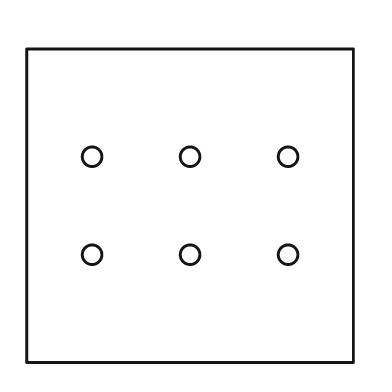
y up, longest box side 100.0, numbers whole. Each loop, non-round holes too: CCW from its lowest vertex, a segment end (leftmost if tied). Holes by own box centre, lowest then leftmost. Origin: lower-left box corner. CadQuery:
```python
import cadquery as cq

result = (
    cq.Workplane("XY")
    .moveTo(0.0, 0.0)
    .lineTo(100.0, 0.0)
    .lineTo(100.0, 96.0)
    .lineTo(0.0, 96.0)
    .close()
    .moveTo(20.0, 33.0)
    .circle(3.0)
    .moveTo(50.0, 33.0)
    .circle(3.0)
    .moveTo(80.0, 33.0)
    .circle(3.0)
    .moveTo(20.0, 63.0)
    .circle(3.0)
    .moveTo(50.0, 63.0)
    .circle(3.0)
    .moveTo(80.0, 63.0)
    .circle(3.0)
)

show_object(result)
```